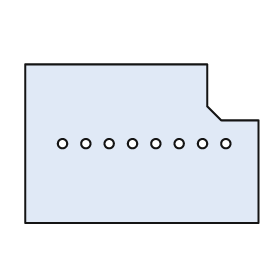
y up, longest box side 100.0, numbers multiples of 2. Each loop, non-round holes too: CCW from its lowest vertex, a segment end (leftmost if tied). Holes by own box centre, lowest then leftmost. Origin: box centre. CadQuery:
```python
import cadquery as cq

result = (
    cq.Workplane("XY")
    .moveTo(-50.0, -34.0)
    .lineTo(50.0, -34.0)
    .lineTo(50.0, 10.0)
    .lineTo(34.0, 10.0)
    .lineTo(28.0, 16.0)
    .lineTo(28.0, 34.0)
    .lineTo(-50.0, 34.0)
    .close()
    .moveTo(-34.0, 0.0)
    .circle(2.0)
    .moveTo(-24.0, 0.0)
    .circle(2.0)
    .moveTo(-14.0, 0.0)
    .circle(2.0)
    .moveTo(-4.0, 0.0)
    .circle(2.0)
    .moveTo(6.0, 0.0)
    .circle(2.0)
    .moveTo(16.0, 0.0)
    .circle(2.0)
    .moveTo(26.0, 0.0)
    .circle(2.0)
    .moveTo(36.0, 0.0)
    .circle(2.0)
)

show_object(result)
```